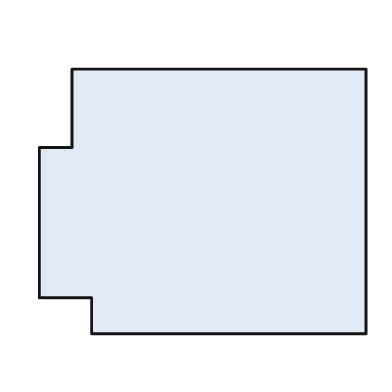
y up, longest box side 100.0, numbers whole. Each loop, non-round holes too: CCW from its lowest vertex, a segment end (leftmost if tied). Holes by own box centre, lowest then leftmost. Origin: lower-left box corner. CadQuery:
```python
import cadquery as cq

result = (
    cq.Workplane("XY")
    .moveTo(16.0, 0.0)
    .lineTo(100.0, 0.0)
    .lineTo(100.0, 81.0)
    .lineTo(10.0, 81.0)
    .lineTo(10.0, 57.0)
    .lineTo(0.0, 57.0)
    .lineTo(0.0, 11.0)
    .lineTo(16.0, 11.0)
    .close()
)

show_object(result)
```